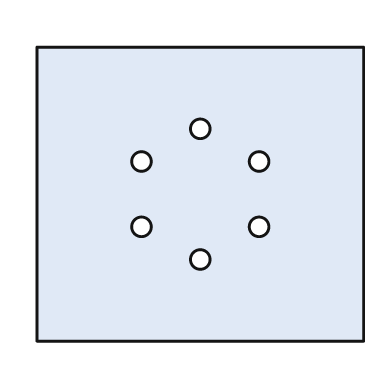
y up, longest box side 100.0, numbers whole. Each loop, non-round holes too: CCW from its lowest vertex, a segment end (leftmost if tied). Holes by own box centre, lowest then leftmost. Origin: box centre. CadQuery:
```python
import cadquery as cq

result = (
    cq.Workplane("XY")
    .moveTo(-50.0, -45.0)
    .lineTo(50.0, -45.0)
    .lineTo(50.0, 45.0)
    .lineTo(-50.0, 45.0)
    .close()
    .moveTo(0.0, -20.0)
    .circle(3.0)
    .moveTo(-18.0, -10.0)
    .circle(3.0)
    .moveTo(18.0, -10.0)
    .circle(3.0)
    .moveTo(-18.0, 10.0)
    .circle(3.0)
    .moveTo(18.0, 10.0)
    .circle(3.0)
    .moveTo(0.0, 20.0)
    .circle(3.0)
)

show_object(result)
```